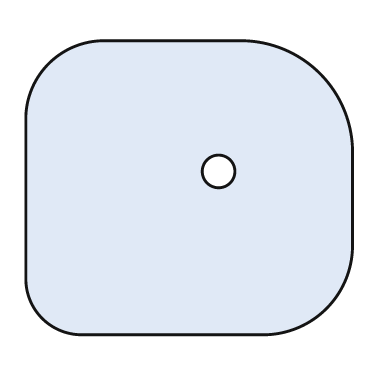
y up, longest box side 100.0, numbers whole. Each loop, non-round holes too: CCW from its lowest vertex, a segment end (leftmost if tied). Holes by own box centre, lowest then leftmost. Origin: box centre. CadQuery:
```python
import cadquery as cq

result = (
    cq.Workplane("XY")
    .moveTo(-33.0, -45.0)
    .lineTo(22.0, -45.0)
    .threePointArc((42.0, -37.0), (50.0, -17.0))
    .lineTo(50.0, 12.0)
    .threePointArc((40.0, 35.0), (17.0, 45.0))
    .lineTo(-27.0, 45.0)
    .threePointArc((-43.0, 38.0), (-50.0, 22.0))
    .lineTo(-50.0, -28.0)
    .threePointArc((-45.0, -40.0), (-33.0, -45.0))
    .close()
    .moveTo(9.0, 5.0)
    .circle(5.0)
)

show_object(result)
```